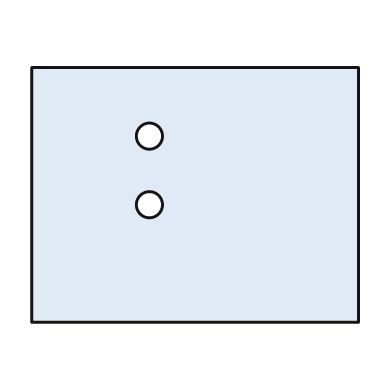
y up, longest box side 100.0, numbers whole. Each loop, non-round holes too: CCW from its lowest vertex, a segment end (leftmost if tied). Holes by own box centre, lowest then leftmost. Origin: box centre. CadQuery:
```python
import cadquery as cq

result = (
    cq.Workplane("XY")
    .moveTo(-50.0, -39.0)
    .lineTo(50.0, -39.0)
    .lineTo(50.0, 39.0)
    .lineTo(-50.0, 39.0)
    .close()
    .moveTo(-14.0, -3.0)
    .circle(4.0)
    .moveTo(-14.0, 18.0)
    .circle(4.0)
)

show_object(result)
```